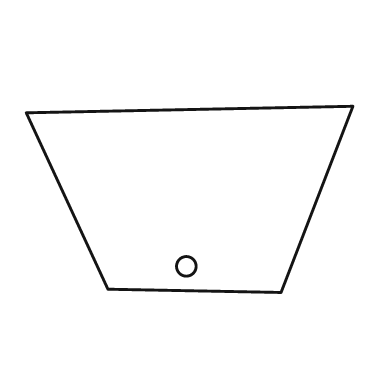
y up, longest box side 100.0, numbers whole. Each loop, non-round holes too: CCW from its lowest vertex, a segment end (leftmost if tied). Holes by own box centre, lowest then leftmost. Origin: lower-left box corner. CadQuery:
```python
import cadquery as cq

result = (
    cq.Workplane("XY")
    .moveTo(78.0, 0.0)
    .lineTo(100.0, 57.0)
    .lineTo(0.0, 55.0)
    .lineTo(25.0, 1.0)
    .close()
    .moveTo(49.0, 8.0)
    .circle(3.0)
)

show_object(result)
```